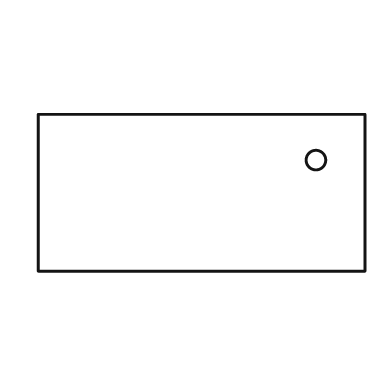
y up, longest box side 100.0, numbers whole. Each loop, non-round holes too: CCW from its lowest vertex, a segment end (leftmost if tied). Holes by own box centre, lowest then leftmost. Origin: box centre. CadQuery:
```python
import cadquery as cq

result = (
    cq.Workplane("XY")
    .moveTo(-50.0, -24.0)
    .lineTo(50.0, -24.0)
    .lineTo(50.0, 24.0)
    .lineTo(-50.0, 24.0)
    .close()
    .moveTo(35.0, 10.0)
    .circle(3.0)
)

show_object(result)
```